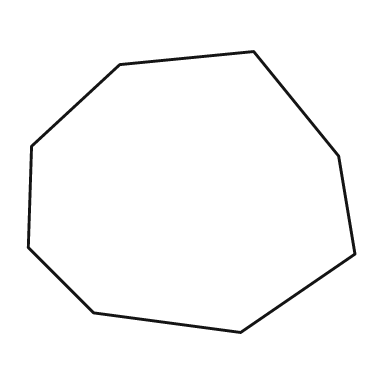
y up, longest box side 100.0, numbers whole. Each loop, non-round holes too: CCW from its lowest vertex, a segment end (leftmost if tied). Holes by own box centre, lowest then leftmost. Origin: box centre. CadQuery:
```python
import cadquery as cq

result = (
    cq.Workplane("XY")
    .moveTo(15.0, -43.0)
    .lineTo(50.0, -19.0)
    .lineTo(45.0, 11.0)
    .lineTo(19.0, 43.0)
    .lineTo(-22.0, 39.0)
    .lineTo(-49.0, 14.0)
    .lineTo(-50.0, -17.0)
    .lineTo(-30.0, -37.0)
    .close()
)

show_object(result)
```